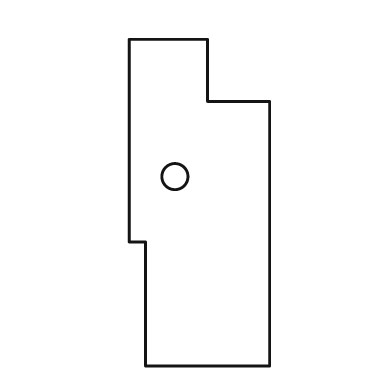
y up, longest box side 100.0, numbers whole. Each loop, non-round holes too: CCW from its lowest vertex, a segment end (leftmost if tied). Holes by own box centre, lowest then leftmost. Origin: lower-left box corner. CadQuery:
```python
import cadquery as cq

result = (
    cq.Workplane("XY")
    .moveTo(5.0, 0.0)
    .lineTo(43.0, 0.0)
    .lineTo(43.0, 81.0)
    .lineTo(24.0, 81.0)
    .lineTo(24.0, 100.0)
    .lineTo(0.0, 100.0)
    .lineTo(0.0, 38.0)
    .lineTo(5.0, 38.0)
    .close()
    .moveTo(14.0, 58.0)
    .circle(4.0)
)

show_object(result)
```